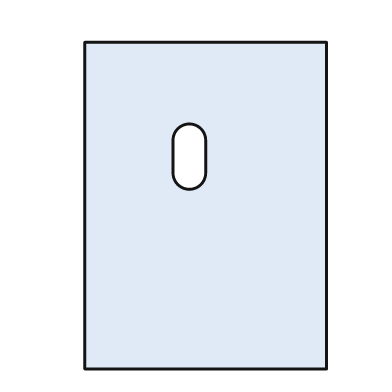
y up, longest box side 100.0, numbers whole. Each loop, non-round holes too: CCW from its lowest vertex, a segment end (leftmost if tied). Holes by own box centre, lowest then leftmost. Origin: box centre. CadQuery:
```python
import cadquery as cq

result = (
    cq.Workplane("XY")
    .moveTo(-37.0, -50.0)
    .lineTo(37.0, -50.0)
    .lineTo(37.0, 50.0)
    .lineTo(-37.0, 50.0)
    .close()
    .moveTo(-10.0, 10.0)
    .threePointArc((-5.0, 5.0), (0.0, 10.0))
    .lineTo(0.0, 20.0)
    .threePointArc((-5.0, 25.0), (-10.0, 20.0))
    .close()
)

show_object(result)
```